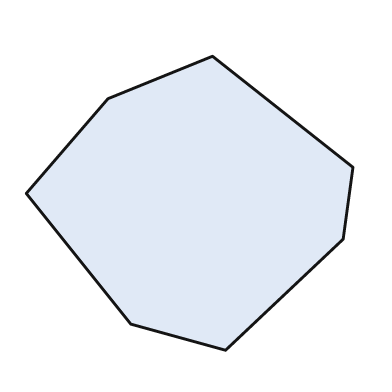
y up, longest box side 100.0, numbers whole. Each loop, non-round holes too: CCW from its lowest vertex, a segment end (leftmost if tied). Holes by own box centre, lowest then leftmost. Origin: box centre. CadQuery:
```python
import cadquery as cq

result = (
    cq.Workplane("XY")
    .moveTo(11.0, -45.0)
    .lineTo(47.0, -11.0)
    .lineTo(50.0, 11.0)
    .lineTo(7.0, 45.0)
    .lineTo(-25.0, 32.0)
    .lineTo(-50.0, 3.0)
    .lineTo(-18.0, -37.0)
    .close()
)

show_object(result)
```